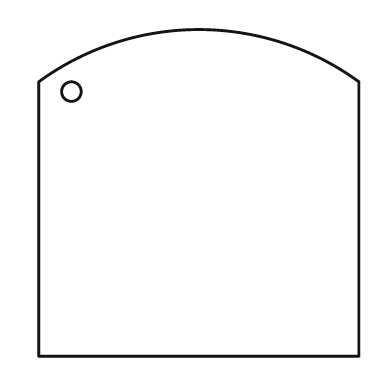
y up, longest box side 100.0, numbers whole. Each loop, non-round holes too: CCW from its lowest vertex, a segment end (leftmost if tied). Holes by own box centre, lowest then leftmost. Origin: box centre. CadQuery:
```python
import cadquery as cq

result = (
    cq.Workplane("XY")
    .moveTo(-49.0, -50.0)
    .lineTo(49.0, -50.0)
    .lineTo(49.0, 34.0)
    .threePointArc((0.0, 50.0), (-49.0, 34.0))
    .close()
    .moveTo(-39.0, 31.0)
    .circle(3.0)
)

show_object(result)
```